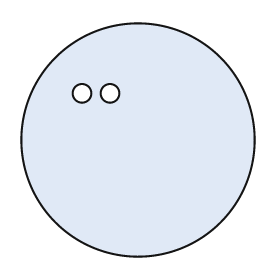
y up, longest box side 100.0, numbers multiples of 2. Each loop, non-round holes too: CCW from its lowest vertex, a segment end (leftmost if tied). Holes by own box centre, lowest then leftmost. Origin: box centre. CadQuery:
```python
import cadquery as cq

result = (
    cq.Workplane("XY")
    .moveTo(0.0, 0.0)
    .circle(50.0)
    .moveTo(-24.0, 20.0)
    .circle(4.0)
    .moveTo(-12.0, 20.0)
    .circle(4.0)
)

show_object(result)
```